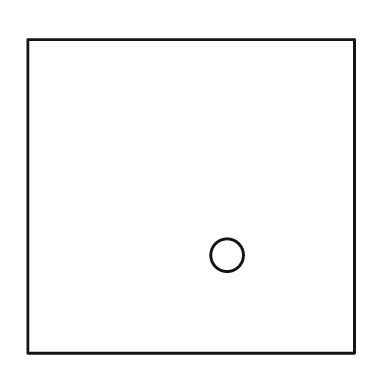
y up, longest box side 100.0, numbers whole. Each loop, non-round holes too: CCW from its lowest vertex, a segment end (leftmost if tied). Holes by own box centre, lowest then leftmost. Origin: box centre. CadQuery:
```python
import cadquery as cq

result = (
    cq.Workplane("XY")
    .moveTo(-50.0, -48.0)
    .lineTo(50.0, -48.0)
    .lineTo(50.0, 48.0)
    .lineTo(-50.0, 48.0)
    .close()
    .moveTo(11.0, -18.0)
    .circle(5.0)
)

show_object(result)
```